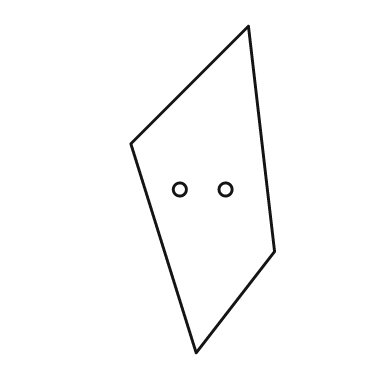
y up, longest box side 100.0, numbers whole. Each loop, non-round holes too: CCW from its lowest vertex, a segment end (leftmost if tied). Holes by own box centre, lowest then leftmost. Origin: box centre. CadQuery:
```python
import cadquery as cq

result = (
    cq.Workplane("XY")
    .moveTo(-2.0, -50.0)
    .lineTo(22.0, -19.0)
    .lineTo(14.0, 50.0)
    .lineTo(-22.0, 14.0)
    .close()
    .moveTo(-7.0, 0.0)
    .circle(2.0)
    .moveTo(7.0, 0.0)
    .circle(2.0)
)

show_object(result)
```